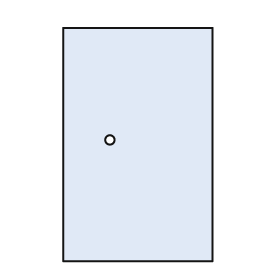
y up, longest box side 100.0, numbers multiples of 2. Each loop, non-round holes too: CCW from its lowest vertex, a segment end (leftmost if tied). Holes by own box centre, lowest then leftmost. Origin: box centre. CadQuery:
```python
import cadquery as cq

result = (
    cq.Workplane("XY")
    .moveTo(-32.0, -50.0)
    .lineTo(32.0, -50.0)
    .lineTo(32.0, 50.0)
    .lineTo(-32.0, 50.0)
    .close()
    .moveTo(-12.0, 2.0)
    .circle(2.0)
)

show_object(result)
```